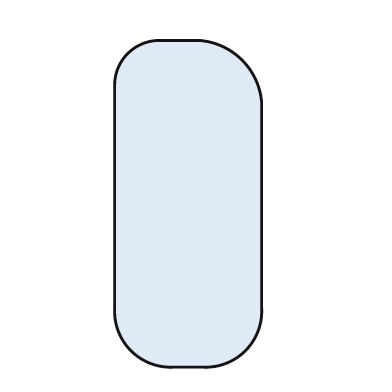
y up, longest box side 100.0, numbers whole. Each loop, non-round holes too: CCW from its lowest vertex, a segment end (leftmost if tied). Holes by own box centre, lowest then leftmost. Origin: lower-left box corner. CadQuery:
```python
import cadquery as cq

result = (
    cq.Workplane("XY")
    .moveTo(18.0, 0.0)
    .lineTo(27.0, 0.0)
    .threePointArc((40.0, 5.0), (45.0, 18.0))
    .lineTo(45.0, 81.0)
    .threePointArc((39.0, 94.0), (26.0, 100.0))
    .lineTo(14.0, 100.0)
    .threePointArc((4.0, 96.0), (0.0, 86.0))
    .lineTo(0.0, 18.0)
    .threePointArc((5.0, 5.0), (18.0, 0.0))
    .close()
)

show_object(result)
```